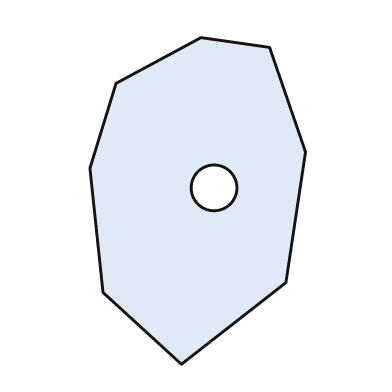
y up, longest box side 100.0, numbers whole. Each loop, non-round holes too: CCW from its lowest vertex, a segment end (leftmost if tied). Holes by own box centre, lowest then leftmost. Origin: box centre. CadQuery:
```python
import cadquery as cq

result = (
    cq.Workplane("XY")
    .moveTo(-5.0, -50.0)
    .lineTo(27.0, -25.0)
    .lineTo(33.0, 15.0)
    .lineTo(22.0, 47.0)
    .lineTo(1.0, 50.0)
    .lineTo(-25.0, 36.0)
    .lineTo(-33.0, 10.0)
    .lineTo(-29.0, -28.0)
    .close()
    .moveTo(5.0, 4.0)
    .circle(7.0)
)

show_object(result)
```